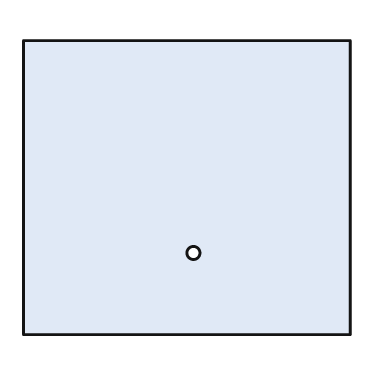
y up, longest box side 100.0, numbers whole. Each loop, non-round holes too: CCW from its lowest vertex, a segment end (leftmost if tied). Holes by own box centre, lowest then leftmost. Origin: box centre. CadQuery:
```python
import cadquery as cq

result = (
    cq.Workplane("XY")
    .moveTo(-50.0, -45.0)
    .lineTo(50.0, -45.0)
    .lineTo(50.0, 45.0)
    .lineTo(-50.0, 45.0)
    .close()
    .moveTo(2.0, -20.0)
    .circle(2.0)
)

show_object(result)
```